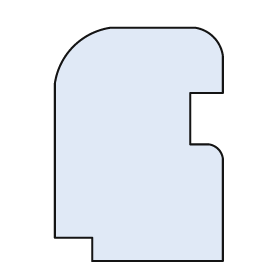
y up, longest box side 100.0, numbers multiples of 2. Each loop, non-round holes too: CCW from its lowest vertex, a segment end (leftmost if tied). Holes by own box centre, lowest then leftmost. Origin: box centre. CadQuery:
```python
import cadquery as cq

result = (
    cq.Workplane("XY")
    .moveTo(-20.0, -50.0)
    .lineTo(36.0, -50.0)
    .lineTo(36.0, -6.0)
    .threePointArc((34.0, -2.0), (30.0, 0.0))
    .lineTo(22.0, 0.0)
    .lineTo(22.0, 22.0)
    .lineTo(36.0, 22.0)
    .lineTo(36.0, 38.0)
    .threePointArc((32.0, 46.0), (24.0, 50.0))
    .lineTo(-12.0, 50.0)
    .threePointArc((-28.0, 42.0), (-36.0, 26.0))
    .lineTo(-36.0, -40.0)
    .lineTo(-20.0, -40.0)
    .close()
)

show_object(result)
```